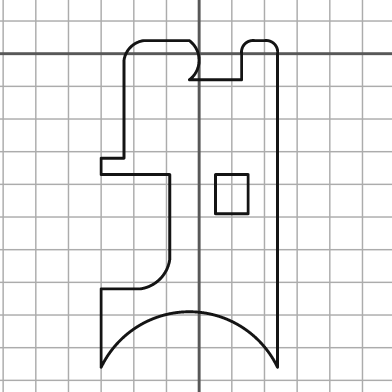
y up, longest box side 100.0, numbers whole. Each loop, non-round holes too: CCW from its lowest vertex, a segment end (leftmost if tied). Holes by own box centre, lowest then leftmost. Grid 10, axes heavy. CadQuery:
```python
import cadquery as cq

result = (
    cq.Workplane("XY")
    .moveTo(-30.0, -96.0)
    .threePointArc((-3.0, -79.0), (24.0, -96.0))
    .lineTo(24.0, 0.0)
    .threePointArc((23.0, 3.0), (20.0, 4.0))
    .lineTo(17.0, 4.0)
    .threePointArc((14.0, 3.0), (13.0, 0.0))
    .lineTo(13.0, -8.0)
    .lineTo(-3.0, -8.0)
    .threePointArc((0.0, -2.0), (-3.0, 4.0))
    .lineTo(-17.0, 4.0)
    .threePointArc((-21.0, 2.0), (-23.0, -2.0))
    .lineTo(-23.0, -32.0)
    .lineTo(-30.0, -32.0)
    .lineTo(-30.0, -37.0)
    .lineTo(-9.0, -37.0)
    .lineTo(-9.0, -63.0)
    .threePointArc((-12.0, -69.0), (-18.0, -72.0))
    .lineTo(-30.0, -72.0)
    .close()
    .moveTo(5.0, -49.0)
    .lineTo(15.0, -49.0)
    .lineTo(15.0, -37.0)
    .lineTo(5.0, -37.0)
    .close()
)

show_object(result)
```